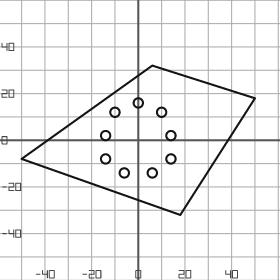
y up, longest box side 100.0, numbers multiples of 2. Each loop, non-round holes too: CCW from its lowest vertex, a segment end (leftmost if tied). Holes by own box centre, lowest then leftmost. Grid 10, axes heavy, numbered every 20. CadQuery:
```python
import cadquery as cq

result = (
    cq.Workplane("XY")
    .moveTo(18.0, -32.0)
    .lineTo(50.0, 18.0)
    .lineTo(6.0, 32.0)
    .lineTo(-50.0, -8.0)
    .close()
    .moveTo(-6.0, -14.0)
    .circle(2.0)
    .moveTo(6.0, -14.0)
    .circle(2.0)
    .moveTo(-14.0, -8.0)
    .circle(2.0)
    .moveTo(14.0, -8.0)
    .circle(2.0)
    .moveTo(-14.0, 2.0)
    .circle(2.0)
    .moveTo(14.0, 2.0)
    .circle(2.0)
    .moveTo(-10.0, 12.0)
    .circle(2.0)
    .moveTo(10.0, 12.0)
    .circle(2.0)
    .moveTo(0.0, 16.0)
    .circle(2.0)
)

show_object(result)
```